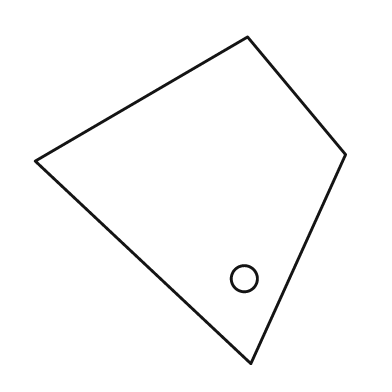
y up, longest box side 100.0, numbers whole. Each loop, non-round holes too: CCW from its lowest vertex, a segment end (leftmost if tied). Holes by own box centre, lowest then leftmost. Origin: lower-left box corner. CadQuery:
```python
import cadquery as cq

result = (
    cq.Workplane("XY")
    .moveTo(66.0, 0.0)
    .lineTo(95.0, 64.0)
    .lineTo(65.0, 100.0)
    .lineTo(0.0, 62.0)
    .close()
    .moveTo(64.0, 26.0)
    .circle(4.0)
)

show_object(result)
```